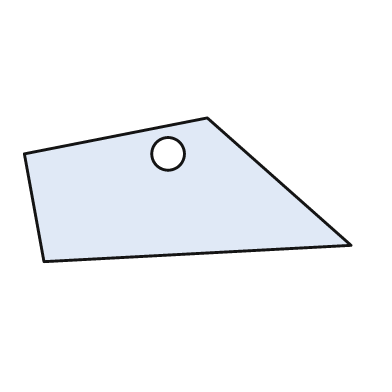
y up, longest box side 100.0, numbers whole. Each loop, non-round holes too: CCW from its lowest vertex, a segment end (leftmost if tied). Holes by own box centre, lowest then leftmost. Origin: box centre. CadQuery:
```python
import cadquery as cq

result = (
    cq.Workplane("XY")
    .moveTo(-44.0, -22.0)
    .lineTo(50.0, -17.0)
    .lineTo(6.0, 22.0)
    .lineTo(-50.0, 11.0)
    .close()
    .moveTo(-6.0, 11.0)
    .circle(5.0)
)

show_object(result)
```